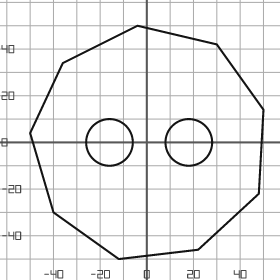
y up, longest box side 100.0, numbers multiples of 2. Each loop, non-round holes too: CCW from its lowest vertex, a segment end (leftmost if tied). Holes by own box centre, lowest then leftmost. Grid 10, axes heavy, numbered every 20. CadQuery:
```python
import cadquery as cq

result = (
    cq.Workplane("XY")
    .moveTo(-12.0, -50.0)
    .lineTo(22.0, -46.0)
    .lineTo(48.0, -22.0)
    .lineTo(50.0, 14.0)
    .lineTo(30.0, 42.0)
    .lineTo(-4.0, 50.0)
    .lineTo(-36.0, 34.0)
    .lineTo(-50.0, 4.0)
    .lineTo(-40.0, -30.0)
    .close()
    .moveTo(-16.0, 0.0)
    .circle(10.0)
    .moveTo(18.0, 0.0)
    .circle(10.0)
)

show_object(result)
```